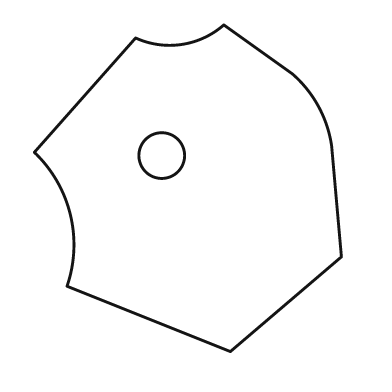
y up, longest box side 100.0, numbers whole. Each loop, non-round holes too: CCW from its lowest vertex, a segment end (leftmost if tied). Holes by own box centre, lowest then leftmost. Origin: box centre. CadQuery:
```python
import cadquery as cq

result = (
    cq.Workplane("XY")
    .moveTo(13.0, -50.0)
    .lineTo(47.0, -21.0)
    .lineTo(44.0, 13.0)
    .threePointArc((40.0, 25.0), (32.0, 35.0))
    .lineTo(11.0, 50.0)
    .threePointArc((-2.0, 44.0), (-16.0, 46.0))
    .lineTo(-47.0, 11.0)
    .threePointArc((-36.0, -8.0), (-37.0, -30.0))
    .close()
    .moveTo(-8.0, 10.0)
    .circle(7.0)
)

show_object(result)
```